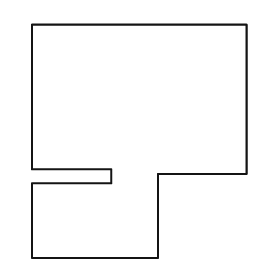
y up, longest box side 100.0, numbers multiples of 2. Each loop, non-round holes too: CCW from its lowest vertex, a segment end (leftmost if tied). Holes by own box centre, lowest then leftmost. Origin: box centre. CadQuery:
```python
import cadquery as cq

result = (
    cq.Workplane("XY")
    .moveTo(-46.0, -50.0)
    .lineTo(8.0, -50.0)
    .lineTo(8.0, -14.0)
    .lineTo(46.0, -14.0)
    .lineTo(46.0, 50.0)
    .lineTo(-46.0, 50.0)
    .lineTo(-46.0, -12.0)
    .lineTo(-12.0, -12.0)
    .lineTo(-12.0, -18.0)
    .lineTo(-46.0, -18.0)
    .close()
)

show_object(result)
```